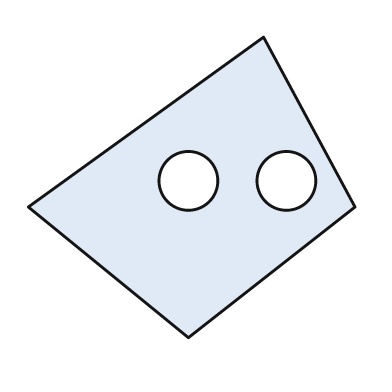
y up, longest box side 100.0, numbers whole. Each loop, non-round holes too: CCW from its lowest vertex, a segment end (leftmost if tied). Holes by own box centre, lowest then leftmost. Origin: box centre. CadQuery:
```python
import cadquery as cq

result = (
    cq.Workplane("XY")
    .moveTo(-1.0, -46.0)
    .lineTo(50.0, -6.0)
    .lineTo(22.0, 46.0)
    .lineTo(-50.0, -6.0)
    .close()
    .moveTo(-1.0, 2.0)
    .circle(9.0)
    .moveTo(29.0, 2.0)
    .circle(9.0)
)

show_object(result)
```